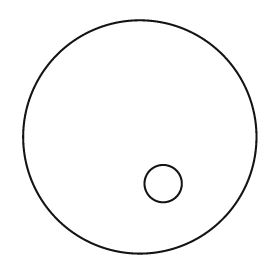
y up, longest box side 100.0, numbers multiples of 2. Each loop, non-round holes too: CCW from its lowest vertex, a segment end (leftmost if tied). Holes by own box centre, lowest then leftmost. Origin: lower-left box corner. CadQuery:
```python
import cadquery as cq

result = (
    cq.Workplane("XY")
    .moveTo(50.0, 50.0)
    .circle(50.0)
    .moveTo(60.0, 30.0)
    .circle(8.0)
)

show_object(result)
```